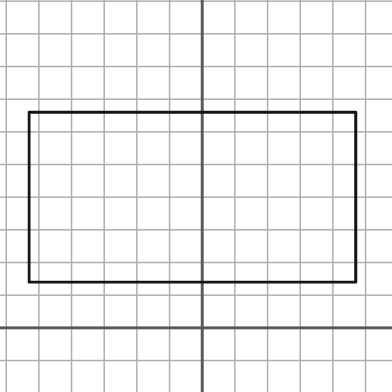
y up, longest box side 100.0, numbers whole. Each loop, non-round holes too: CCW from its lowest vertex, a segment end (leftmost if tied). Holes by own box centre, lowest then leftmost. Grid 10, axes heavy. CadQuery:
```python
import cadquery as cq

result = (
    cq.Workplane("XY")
    .moveTo(-53.0, 14.0)
    .lineTo(47.0, 14.0)
    .lineTo(47.0, 66.0)
    .lineTo(-53.0, 66.0)
    .close()
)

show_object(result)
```